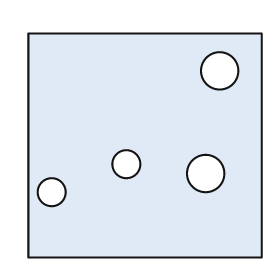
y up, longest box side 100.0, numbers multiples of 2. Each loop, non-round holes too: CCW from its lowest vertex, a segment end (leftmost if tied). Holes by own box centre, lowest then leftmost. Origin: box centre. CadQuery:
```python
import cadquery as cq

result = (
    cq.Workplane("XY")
    .moveTo(-50.0, -48.0)
    .lineTo(50.0, -48.0)
    .lineTo(50.0, 48.0)
    .lineTo(-50.0, 48.0)
    .close()
    .moveTo(-40.0, -20.0)
    .circle(6.0)
    .moveTo(26.0, -12.0)
    .circle(8.0)
    .moveTo(-8.0, -8.0)
    .circle(6.0)
    .moveTo(32.0, 32.0)
    .circle(8.0)
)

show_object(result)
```